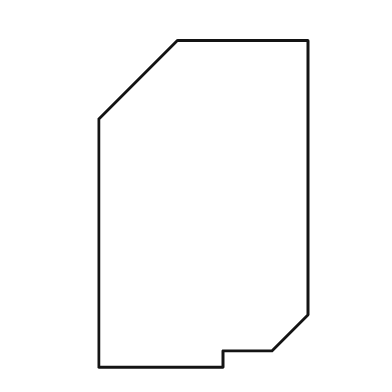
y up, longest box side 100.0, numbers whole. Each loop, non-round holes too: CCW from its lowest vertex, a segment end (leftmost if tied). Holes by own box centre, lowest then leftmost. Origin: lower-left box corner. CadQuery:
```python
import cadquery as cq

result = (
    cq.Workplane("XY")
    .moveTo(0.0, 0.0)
    .lineTo(38.0, 0.0)
    .lineTo(38.0, 5.0)
    .lineTo(53.0, 5.0)
    .lineTo(64.0, 16.0)
    .lineTo(64.0, 100.0)
    .lineTo(24.0, 100.0)
    .lineTo(0.0, 76.0)
    .close()
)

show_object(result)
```